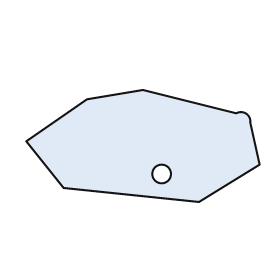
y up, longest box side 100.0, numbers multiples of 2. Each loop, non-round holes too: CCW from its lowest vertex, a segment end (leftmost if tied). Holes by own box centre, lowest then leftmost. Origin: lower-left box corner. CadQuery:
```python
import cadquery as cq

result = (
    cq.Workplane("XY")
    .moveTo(74.0, 0.0)
    .lineTo(100.0, 16.0)
    .lineTo(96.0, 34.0)
    .threePointArc((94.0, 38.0), (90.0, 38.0))
    .lineTo(50.0, 48.0)
    .lineTo(26.0, 44.0)
    .lineTo(0.0, 26.0)
    .lineTo(16.0, 6.0)
    .close()
    .moveTo(58.0, 12.0)
    .circle(4.0)
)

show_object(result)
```